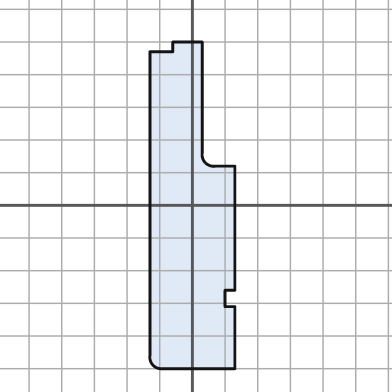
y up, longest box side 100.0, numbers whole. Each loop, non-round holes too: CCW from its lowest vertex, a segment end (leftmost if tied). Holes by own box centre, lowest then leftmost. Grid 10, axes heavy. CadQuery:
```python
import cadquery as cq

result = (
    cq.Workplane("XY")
    .moveTo(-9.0, -50.0)
    .lineTo(13.0, -50.0)
    .lineTo(13.0, -31.0)
    .lineTo(10.0, -31.0)
    .lineTo(10.0, -26.0)
    .lineTo(13.0, -26.0)
    .lineTo(13.0, 12.0)
    .lineTo(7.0, 12.0)
    .threePointArc((4.0, 13.0), (3.0, 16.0))
    .lineTo(3.0, 50.0)
    .lineTo(-6.0, 50.0)
    .lineTo(-6.0, 47.0)
    .lineTo(-13.0, 47.0)
    .lineTo(-13.0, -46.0)
    .threePointArc((-12.0, -49.0), (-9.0, -50.0))
    .close()
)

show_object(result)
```